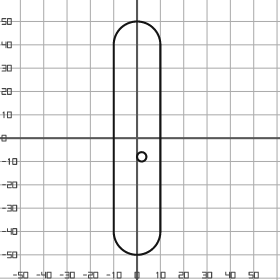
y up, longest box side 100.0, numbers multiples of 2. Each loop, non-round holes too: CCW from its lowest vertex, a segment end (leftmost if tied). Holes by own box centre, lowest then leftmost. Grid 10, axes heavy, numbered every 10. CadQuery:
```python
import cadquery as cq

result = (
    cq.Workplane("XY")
    .moveTo(-10.0, -40.0)
    .threePointArc((0.0, -50.0), (10.0, -40.0))
    .lineTo(10.0, 40.0)
    .threePointArc((0.0, 50.0), (-10.0, 40.0))
    .close()
    .moveTo(2.0, -8.0)
    .circle(2.0)
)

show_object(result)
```